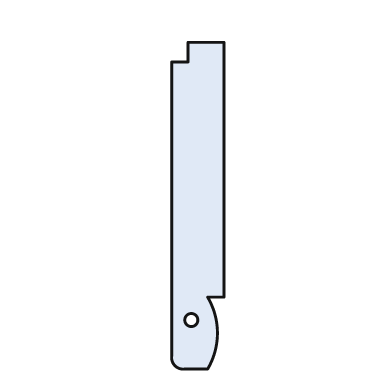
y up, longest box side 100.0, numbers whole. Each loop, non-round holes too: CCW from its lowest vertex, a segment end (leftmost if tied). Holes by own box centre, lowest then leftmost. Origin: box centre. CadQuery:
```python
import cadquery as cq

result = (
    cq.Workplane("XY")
    .moveTo(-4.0, -50.0)
    .lineTo(3.0, -50.0)
    .threePointArc((6.0, -39.0), (3.0, -28.0))
    .lineTo(8.0, -28.0)
    .lineTo(8.0, 50.0)
    .lineTo(-3.0, 50.0)
    .lineTo(-3.0, 44.0)
    .lineTo(-8.0, 44.0)
    .lineTo(-8.0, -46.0)
    .threePointArc((-7.0, -49.0), (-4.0, -50.0))
    .close()
    .moveTo(-2.0, -35.0)
    .circle(2.0)
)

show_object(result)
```